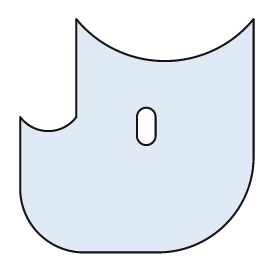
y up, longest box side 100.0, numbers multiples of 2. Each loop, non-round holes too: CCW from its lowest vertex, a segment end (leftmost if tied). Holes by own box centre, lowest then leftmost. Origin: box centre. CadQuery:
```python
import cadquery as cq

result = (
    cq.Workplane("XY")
    .moveTo(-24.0, -50.0)
    .lineTo(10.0, -50.0)
    .threePointArc((38.0, -38.0), (50.0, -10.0))
    .lineTo(50.0, 50.0)
    .threePointArc((12.0, 32.0), (-26.0, 50.0))
    .lineTo(-26.0, 8.0)
    .threePointArc((-38.0, 2.0), (-50.0, 8.0))
    .lineTo(-50.0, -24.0)
    .threePointArc((-42.0, -42.0), (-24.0, -50.0))
    .close()
    .moveTo(0.0, 0.0)
    .threePointArc((4.0, -4.0), (8.0, 0.0))
    .lineTo(8.0, 8.0)
    .threePointArc((4.0, 12.0), (0.0, 8.0))
    .close()
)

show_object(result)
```